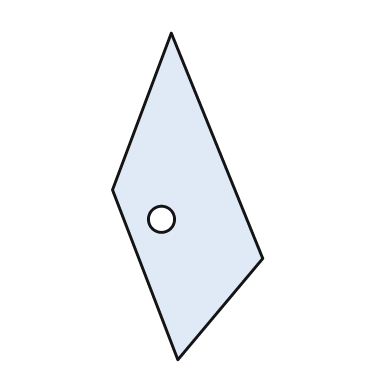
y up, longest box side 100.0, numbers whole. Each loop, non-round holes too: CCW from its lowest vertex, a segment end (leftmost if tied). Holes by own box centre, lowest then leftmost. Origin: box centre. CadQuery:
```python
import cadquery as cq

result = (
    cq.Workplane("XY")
    .moveTo(-3.0, -50.0)
    .lineTo(23.0, -19.0)
    .lineTo(-5.0, 50.0)
    .lineTo(-23.0, 2.0)
    .close()
    .moveTo(-8.0, -7.0)
    .circle(4.0)
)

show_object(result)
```